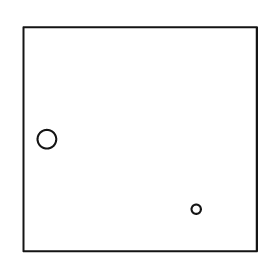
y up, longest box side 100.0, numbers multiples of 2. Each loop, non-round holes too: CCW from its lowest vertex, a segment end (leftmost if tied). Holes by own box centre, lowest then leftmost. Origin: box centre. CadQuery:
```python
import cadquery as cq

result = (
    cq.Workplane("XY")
    .moveTo(-50.0, -48.0)
    .lineTo(50.0, -48.0)
    .lineTo(50.0, 48.0)
    .lineTo(-50.0, 48.0)
    .close()
    .moveTo(24.0, -30.0)
    .circle(2.0)
    .moveTo(-40.0, 0.0)
    .circle(4.0)
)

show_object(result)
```